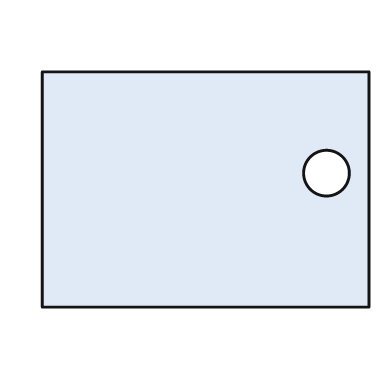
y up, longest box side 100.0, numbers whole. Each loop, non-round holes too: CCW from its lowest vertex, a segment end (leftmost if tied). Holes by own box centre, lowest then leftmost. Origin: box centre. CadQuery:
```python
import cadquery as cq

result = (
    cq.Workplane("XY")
    .moveTo(-50.0, -36.0)
    .lineTo(50.0, -36.0)
    .lineTo(50.0, 36.0)
    .lineTo(-50.0, 36.0)
    .close()
    .moveTo(37.0, 5.0)
    .circle(7.0)
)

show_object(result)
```